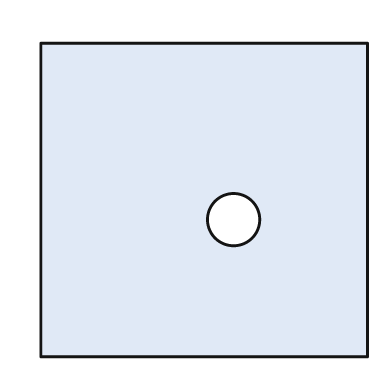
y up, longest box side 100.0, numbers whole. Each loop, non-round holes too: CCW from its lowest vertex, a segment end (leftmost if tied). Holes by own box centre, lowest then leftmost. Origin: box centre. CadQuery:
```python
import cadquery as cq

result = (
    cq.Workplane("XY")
    .moveTo(-50.0, -48.0)
    .lineTo(50.0, -48.0)
    .lineTo(50.0, 48.0)
    .lineTo(-50.0, 48.0)
    .close()
    .moveTo(9.0, -6.0)
    .circle(8.0)
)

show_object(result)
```